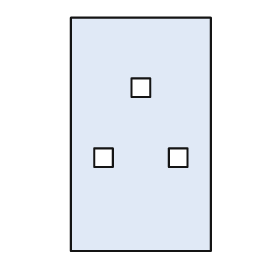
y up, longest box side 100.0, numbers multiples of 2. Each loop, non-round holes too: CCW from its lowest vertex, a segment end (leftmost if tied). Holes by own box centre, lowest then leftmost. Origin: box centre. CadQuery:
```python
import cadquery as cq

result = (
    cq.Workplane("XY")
    .moveTo(-30.0, -50.0)
    .lineTo(30.0, -50.0)
    .lineTo(30.0, 50.0)
    .lineTo(-30.0, 50.0)
    .close()
    .moveTo(-20.0, -14.0)
    .lineTo(-12.0, -14.0)
    .lineTo(-12.0, -6.0)
    .lineTo(-20.0, -6.0)
    .close()
    .moveTo(12.0, -14.0)
    .lineTo(20.0, -14.0)
    .lineTo(20.0, -6.0)
    .lineTo(12.0, -6.0)
    .close()
    .moveTo(-4.0, 16.0)
    .lineTo(4.0, 16.0)
    .lineTo(4.0, 24.0)
    .lineTo(-4.0, 24.0)
    .close()
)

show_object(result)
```